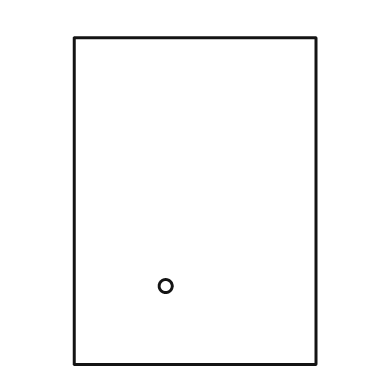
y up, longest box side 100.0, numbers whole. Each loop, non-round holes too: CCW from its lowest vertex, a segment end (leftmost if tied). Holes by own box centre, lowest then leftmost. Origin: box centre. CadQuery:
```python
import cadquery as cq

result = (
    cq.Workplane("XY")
    .moveTo(-37.0, -50.0)
    .lineTo(37.0, -50.0)
    .lineTo(37.0, 50.0)
    .lineTo(-37.0, 50.0)
    .close()
    .moveTo(-9.0, -26.0)
    .circle(2.0)
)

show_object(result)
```